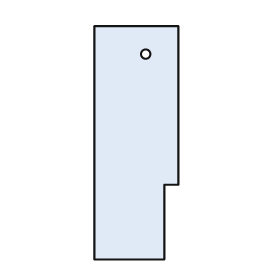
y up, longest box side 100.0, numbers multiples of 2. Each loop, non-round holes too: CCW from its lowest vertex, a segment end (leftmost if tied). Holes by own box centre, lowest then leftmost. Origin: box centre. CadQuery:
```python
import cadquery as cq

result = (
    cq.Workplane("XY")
    .moveTo(-18.0, -50.0)
    .lineTo(12.0, -50.0)
    .lineTo(12.0, -18.0)
    .lineTo(18.0, -18.0)
    .lineTo(18.0, 50.0)
    .lineTo(-18.0, 50.0)
    .close()
    .moveTo(4.0, 38.0)
    .circle(2.0)
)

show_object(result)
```